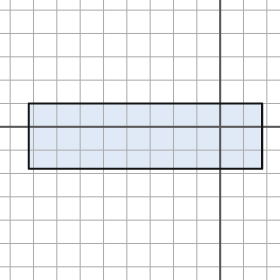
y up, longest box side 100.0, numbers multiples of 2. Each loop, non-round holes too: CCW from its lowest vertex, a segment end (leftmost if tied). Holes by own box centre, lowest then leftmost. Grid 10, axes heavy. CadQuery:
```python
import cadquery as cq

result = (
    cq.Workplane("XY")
    .moveTo(-82.0, -18.0)
    .lineTo(18.0, -18.0)
    .lineTo(18.0, 10.0)
    .lineTo(-82.0, 10.0)
    .close()
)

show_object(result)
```